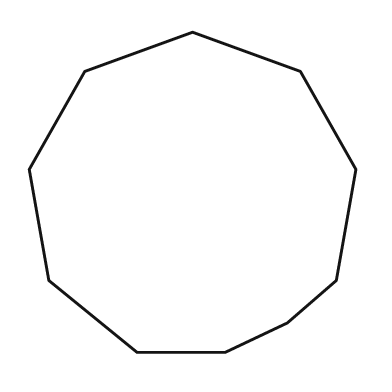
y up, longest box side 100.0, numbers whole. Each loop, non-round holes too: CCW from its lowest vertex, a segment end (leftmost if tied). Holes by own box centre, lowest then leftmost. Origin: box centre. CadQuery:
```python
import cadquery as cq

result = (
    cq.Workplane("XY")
    .moveTo(-17.0, -49.0)
    .lineTo(10.0, -49.0)
    .lineTo(29.0, -40.0)
    .lineTo(44.0, -27.0)
    .lineTo(50.0, 7.0)
    .lineTo(33.0, 37.0)
    .lineTo(0.0, 49.0)
    .lineTo(-33.0, 37.0)
    .lineTo(-50.0, 7.0)
    .lineTo(-44.0, -27.0)
    .close()
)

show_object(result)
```